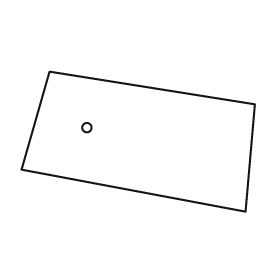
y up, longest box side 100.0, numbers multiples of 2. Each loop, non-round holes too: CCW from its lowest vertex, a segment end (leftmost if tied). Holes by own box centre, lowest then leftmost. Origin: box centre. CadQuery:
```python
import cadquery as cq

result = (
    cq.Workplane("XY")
    .moveTo(46.0, -30.0)
    .lineTo(50.0, 16.0)
    .lineTo(-38.0, 30.0)
    .lineTo(-50.0, -12.0)
    .close()
    .moveTo(-22.0, 6.0)
    .circle(2.0)
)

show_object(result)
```